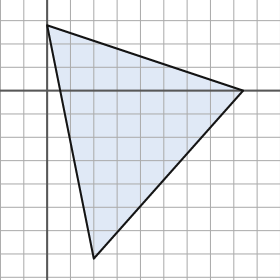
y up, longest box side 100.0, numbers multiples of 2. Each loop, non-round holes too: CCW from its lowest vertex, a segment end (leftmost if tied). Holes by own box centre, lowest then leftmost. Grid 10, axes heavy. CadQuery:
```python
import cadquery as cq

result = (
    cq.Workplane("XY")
    .moveTo(20.0, -72.0)
    .lineTo(84.0, 0.0)
    .lineTo(0.0, 28.0)
    .close()
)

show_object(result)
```